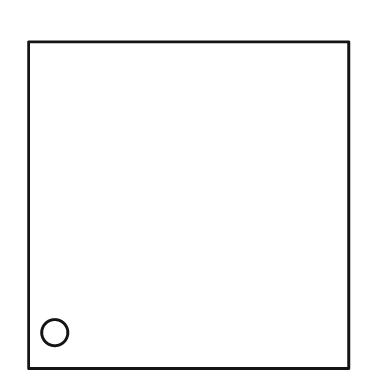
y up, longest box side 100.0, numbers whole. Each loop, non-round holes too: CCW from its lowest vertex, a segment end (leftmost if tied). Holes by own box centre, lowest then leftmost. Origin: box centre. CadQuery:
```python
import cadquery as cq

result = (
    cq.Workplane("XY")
    .moveTo(-49.0, -50.0)
    .lineTo(49.0, -50.0)
    .lineTo(49.0, 50.0)
    .lineTo(-49.0, 50.0)
    .close()
    .moveTo(-41.0, -39.0)
    .circle(4.0)
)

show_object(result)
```